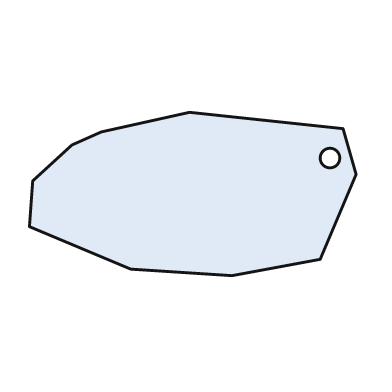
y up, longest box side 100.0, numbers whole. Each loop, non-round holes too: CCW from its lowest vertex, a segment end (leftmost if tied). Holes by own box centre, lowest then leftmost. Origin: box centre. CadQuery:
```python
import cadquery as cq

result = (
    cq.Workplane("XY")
    .moveTo(12.0, -25.0)
    .lineTo(39.0, -20.0)
    .lineTo(50.0, 6.0)
    .lineTo(46.0, 20.0)
    .lineTo(-1.0, 25.0)
    .lineTo(-28.0, 19.0)
    .lineTo(-37.0, 15.0)
    .lineTo(-49.0, 4.0)
    .lineTo(-50.0, -10.0)
    .lineTo(-19.0, -23.0)
    .close()
    .moveTo(42.0, 11.0)
    .circle(3.0)
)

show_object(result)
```